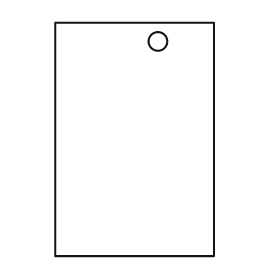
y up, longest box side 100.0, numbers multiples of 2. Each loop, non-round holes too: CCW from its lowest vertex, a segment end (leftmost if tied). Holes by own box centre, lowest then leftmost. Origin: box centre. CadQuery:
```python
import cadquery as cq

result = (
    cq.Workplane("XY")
    .moveTo(-34.0, -50.0)
    .lineTo(34.0, -50.0)
    .lineTo(34.0, 50.0)
    .lineTo(-34.0, 50.0)
    .close()
    .moveTo(10.0, 42.0)
    .circle(4.0)
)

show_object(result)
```